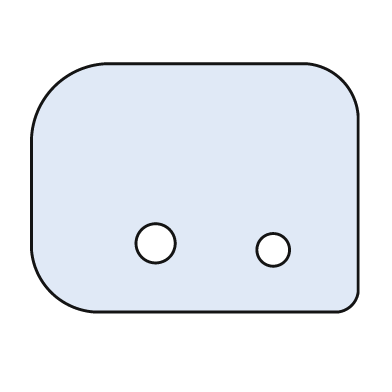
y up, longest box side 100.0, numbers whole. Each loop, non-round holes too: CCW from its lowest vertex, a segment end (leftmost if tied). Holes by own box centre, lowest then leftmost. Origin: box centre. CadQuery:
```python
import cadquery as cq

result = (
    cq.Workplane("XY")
    .moveTo(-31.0, -38.0)
    .lineTo(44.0, -38.0)
    .threePointArc((48.0, -36.0), (50.0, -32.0))
    .lineTo(50.0, 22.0)
    .threePointArc((45.0, 33.0), (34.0, 38.0))
    .lineTo(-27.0, 38.0)
    .threePointArc((-43.0, 31.0), (-50.0, 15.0))
    .lineTo(-50.0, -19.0)
    .threePointArc((-44.0, -32.0), (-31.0, -38.0))
    .close()
    .moveTo(24.0, -19.0)
    .circle(5.0)
    .moveTo(-12.0, -17.0)
    .circle(6.0)
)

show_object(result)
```